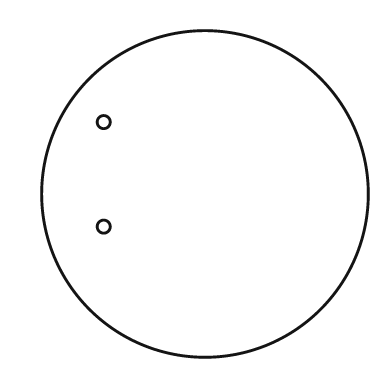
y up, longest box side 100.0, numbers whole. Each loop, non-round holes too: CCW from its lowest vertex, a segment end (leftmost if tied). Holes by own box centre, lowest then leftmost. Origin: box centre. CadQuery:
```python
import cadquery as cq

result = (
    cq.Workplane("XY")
    .moveTo(0.0, 0.0)
    .circle(50.0)
    .moveTo(-31.0, -10.0)
    .circle(2.0)
    .moveTo(-31.0, 22.0)
    .circle(2.0)
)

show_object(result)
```